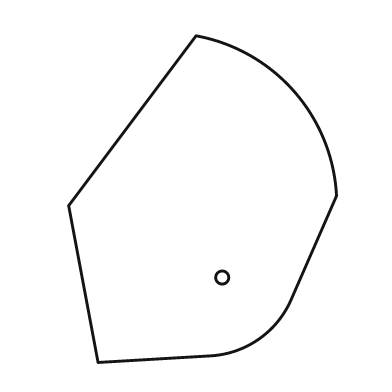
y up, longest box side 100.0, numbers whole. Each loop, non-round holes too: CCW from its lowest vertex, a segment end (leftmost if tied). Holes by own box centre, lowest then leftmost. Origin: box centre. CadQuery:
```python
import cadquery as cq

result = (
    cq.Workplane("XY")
    .moveTo(-32.0, -50.0)
    .lineTo(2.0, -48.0)
    .threePointArc((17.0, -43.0), (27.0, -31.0))
    .lineTo(41.0, 1.0)
    .threePointArc((28.0, 33.0), (-2.0, 50.0))
    .lineTo(-41.0, -2.0)
    .close()
    .moveTo(6.0, -24.0)
    .circle(2.0)
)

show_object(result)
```